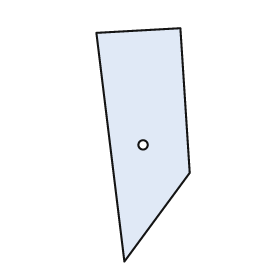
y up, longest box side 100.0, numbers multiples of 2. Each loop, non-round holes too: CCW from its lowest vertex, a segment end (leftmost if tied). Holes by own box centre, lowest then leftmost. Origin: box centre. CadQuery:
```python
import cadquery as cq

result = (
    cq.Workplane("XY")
    .moveTo(-8.0, -50.0)
    .lineTo(20.0, -12.0)
    .lineTo(16.0, 50.0)
    .lineTo(-20.0, 48.0)
    .close()
    .moveTo(0.0, 0.0)
    .circle(2.0)
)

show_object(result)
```